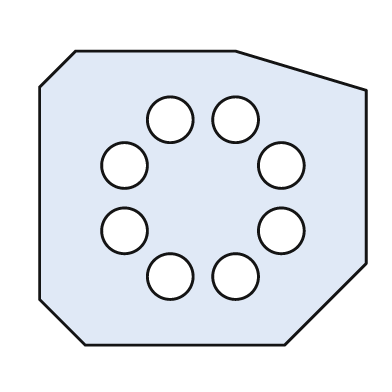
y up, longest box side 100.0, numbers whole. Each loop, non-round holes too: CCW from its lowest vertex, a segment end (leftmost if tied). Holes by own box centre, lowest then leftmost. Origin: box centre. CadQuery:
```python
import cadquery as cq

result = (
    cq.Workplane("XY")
    .moveTo(-36.0, -45.0)
    .lineTo(25.0, -45.0)
    .lineTo(50.0, -20.0)
    .lineTo(50.0, 33.0)
    .lineTo(10.0, 45.0)
    .lineTo(-39.0, 45.0)
    .lineTo(-50.0, 34.0)
    .lineTo(-50.0, -31.0)
    .close()
    .moveTo(-10.0, -24.0)
    .circle(7.0)
    .moveTo(10.0, -24.0)
    .circle(7.0)
    .moveTo(-24.0, -10.0)
    .circle(7.0)
    .moveTo(24.0, -10.0)
    .circle(7.0)
    .moveTo(-24.0, 10.0)
    .circle(7.0)
    .moveTo(24.0, 10.0)
    .circle(7.0)
    .moveTo(-10.0, 24.0)
    .circle(7.0)
    .moveTo(10.0, 24.0)
    .circle(7.0)
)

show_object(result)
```